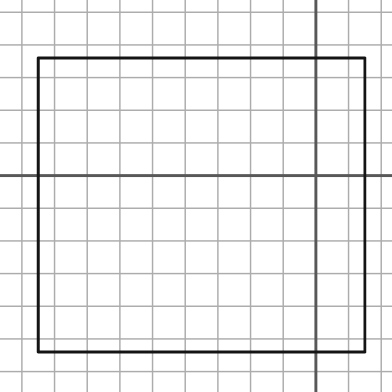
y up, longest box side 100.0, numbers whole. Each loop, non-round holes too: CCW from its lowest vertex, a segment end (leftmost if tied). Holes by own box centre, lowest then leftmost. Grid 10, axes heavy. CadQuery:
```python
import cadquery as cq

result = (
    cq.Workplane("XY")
    .moveTo(-85.0, -54.0)
    .lineTo(15.0, -54.0)
    .lineTo(15.0, 36.0)
    .lineTo(-85.0, 36.0)
    .close()
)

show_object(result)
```